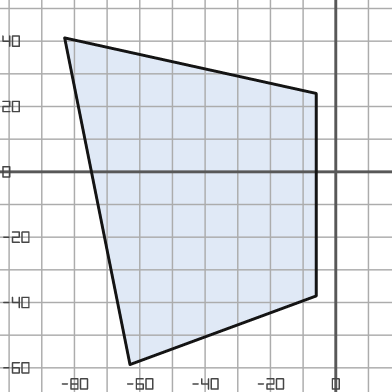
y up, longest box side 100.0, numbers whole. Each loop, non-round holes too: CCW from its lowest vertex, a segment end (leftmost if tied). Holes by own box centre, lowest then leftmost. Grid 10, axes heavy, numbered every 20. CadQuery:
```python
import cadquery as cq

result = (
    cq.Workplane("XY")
    .moveTo(-63.0, -59.0)
    .lineTo(-6.0, -38.0)
    .lineTo(-6.0, 24.0)
    .lineTo(-83.0, 41.0)
    .close()
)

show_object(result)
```